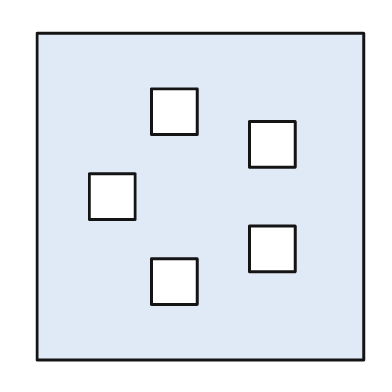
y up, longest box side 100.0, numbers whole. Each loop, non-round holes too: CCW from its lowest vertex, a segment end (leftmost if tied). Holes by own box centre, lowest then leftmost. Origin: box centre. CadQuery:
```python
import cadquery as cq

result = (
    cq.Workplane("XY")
    .moveTo(-50.0, -50.0)
    .lineTo(50.0, -50.0)
    .lineTo(50.0, 50.0)
    .lineTo(-50.0, 50.0)
    .close()
    .moveTo(-15.0, -33.0)
    .lineTo(-1.0, -33.0)
    .lineTo(-1.0, -19.0)
    .lineTo(-15.0, -19.0)
    .close()
    .moveTo(15.0, -23.0)
    .lineTo(29.0, -23.0)
    .lineTo(29.0, -9.0)
    .lineTo(15.0, -9.0)
    .close()
    .moveTo(-34.0, -7.0)
    .lineTo(-20.0, -7.0)
    .lineTo(-20.0, 7.0)
    .lineTo(-34.0, 7.0)
    .close()
    .moveTo(15.0, 9.0)
    .lineTo(29.0, 9.0)
    .lineTo(29.0, 23.0)
    .lineTo(15.0, 23.0)
    .close()
    .moveTo(-15.0, 19.0)
    .lineTo(-1.0, 19.0)
    .lineTo(-1.0, 33.0)
    .lineTo(-15.0, 33.0)
    .close()
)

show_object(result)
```